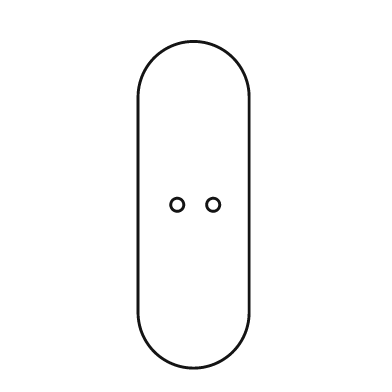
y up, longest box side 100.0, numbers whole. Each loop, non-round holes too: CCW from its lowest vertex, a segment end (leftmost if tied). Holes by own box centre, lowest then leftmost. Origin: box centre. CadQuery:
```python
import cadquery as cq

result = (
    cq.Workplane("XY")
    .moveTo(-17.0, -33.0)
    .threePointArc((0.0, -50.0), (17.0, -33.0))
    .lineTo(17.0, 33.0)
    .threePointArc((0.0, 50.0), (-17.0, 33.0))
    .close()
    .moveTo(-5.0, 0.0)
    .circle(2.0)
    .moveTo(6.0, 0.0)
    .circle(2.0)
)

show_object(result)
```